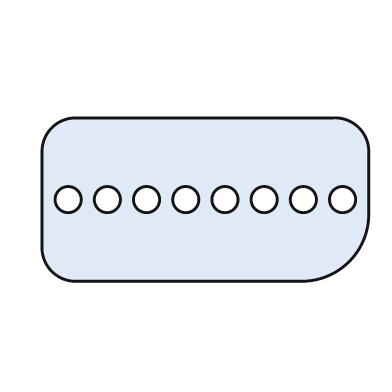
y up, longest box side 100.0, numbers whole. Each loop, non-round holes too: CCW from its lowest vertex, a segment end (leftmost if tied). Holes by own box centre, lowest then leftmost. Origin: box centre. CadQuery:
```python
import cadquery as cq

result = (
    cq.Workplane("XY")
    .moveTo(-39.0, -25.0)
    .lineTo(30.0, -25.0)
    .threePointArc((44.0, -19.0), (50.0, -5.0))
    .lineTo(50.0, 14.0)
    .threePointArc((47.0, 22.0), (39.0, 25.0))
    .lineTo(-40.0, 25.0)
    .threePointArc((-47.0, 22.0), (-50.0, 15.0))
    .lineTo(-50.0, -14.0)
    .threePointArc((-47.0, -22.0), (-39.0, -25.0))
    .close()
    .moveTo(-42.0, 0.0)
    .circle(4.0)
    .moveTo(-30.0, 0.0)
    .circle(4.0)
    .moveTo(-18.0, 0.0)
    .circle(4.0)
    .moveTo(-6.0, 0.0)
    .circle(4.0)
    .moveTo(6.0, 0.0)
    .circle(4.0)
    .moveTo(18.0, 0.0)
    .circle(4.0)
    .moveTo(30.0, 0.0)
    .circle(4.0)
    .moveTo(42.0, 0.0)
    .circle(4.0)
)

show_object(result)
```